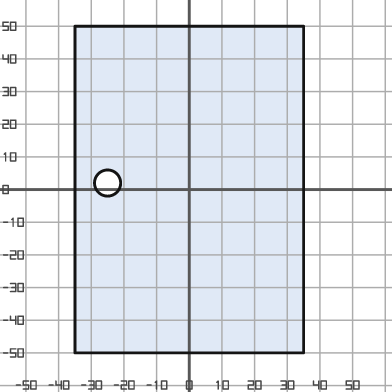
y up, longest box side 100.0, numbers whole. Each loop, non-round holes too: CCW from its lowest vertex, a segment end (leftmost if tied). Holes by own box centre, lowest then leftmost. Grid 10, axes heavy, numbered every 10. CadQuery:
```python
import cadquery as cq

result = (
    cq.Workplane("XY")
    .moveTo(-35.0, -50.0)
    .lineTo(35.0, -50.0)
    .lineTo(35.0, 50.0)
    .lineTo(-35.0, 50.0)
    .close()
    .moveTo(-25.0, 2.0)
    .circle(4.0)
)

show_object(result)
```